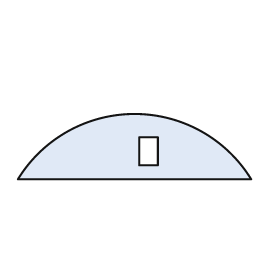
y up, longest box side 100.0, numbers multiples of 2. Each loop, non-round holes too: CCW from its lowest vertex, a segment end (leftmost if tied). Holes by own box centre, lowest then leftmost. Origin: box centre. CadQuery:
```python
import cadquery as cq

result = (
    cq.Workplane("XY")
    .moveTo(-50.0, -14.0)
    .lineTo(50.0, -14.0)
    .threePointArc((0.0, 14.0), (-50.0, -14.0))
    .close()
    .moveTo(2.0, -8.0)
    .lineTo(10.0, -8.0)
    .lineTo(10.0, 4.0)
    .lineTo(2.0, 4.0)
    .close()
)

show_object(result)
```